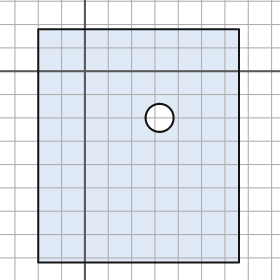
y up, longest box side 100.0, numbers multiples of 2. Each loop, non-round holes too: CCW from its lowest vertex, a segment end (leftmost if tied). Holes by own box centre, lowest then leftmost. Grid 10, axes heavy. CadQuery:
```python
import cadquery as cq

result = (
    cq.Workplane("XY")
    .moveTo(-20.0, -82.0)
    .lineTo(66.0, -82.0)
    .lineTo(66.0, 18.0)
    .lineTo(-20.0, 18.0)
    .close()
    .moveTo(32.0, -20.0)
    .circle(6.0)
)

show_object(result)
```